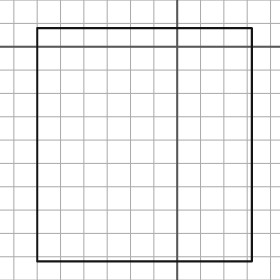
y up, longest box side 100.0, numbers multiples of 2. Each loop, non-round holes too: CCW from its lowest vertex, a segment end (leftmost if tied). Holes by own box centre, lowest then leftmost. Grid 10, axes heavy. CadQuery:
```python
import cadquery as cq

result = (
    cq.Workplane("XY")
    .moveTo(-60.0, -92.0)
    .lineTo(32.0, -92.0)
    .lineTo(32.0, 8.0)
    .lineTo(-60.0, 8.0)
    .close()
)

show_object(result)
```